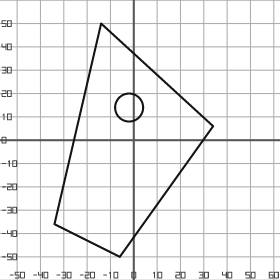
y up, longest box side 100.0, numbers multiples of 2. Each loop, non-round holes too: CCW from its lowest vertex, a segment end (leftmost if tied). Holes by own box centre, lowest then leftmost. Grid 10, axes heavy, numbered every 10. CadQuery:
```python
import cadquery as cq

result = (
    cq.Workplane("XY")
    .moveTo(-6.0, -50.0)
    .lineTo(34.0, 6.0)
    .lineTo(-14.0, 50.0)
    .lineTo(-34.0, -36.0)
    .close()
    .moveTo(-2.0, 14.0)
    .circle(6.0)
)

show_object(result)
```